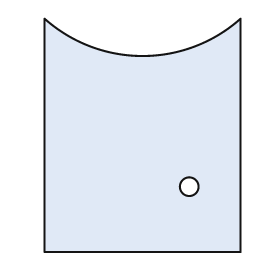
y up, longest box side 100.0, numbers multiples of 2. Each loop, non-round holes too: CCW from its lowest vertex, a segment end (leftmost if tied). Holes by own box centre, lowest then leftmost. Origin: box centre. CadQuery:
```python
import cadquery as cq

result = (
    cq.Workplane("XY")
    .moveTo(-42.0, -50.0)
    .lineTo(42.0, -50.0)
    .lineTo(42.0, 50.0)
    .threePointArc((0.0, 34.0), (-42.0, 50.0))
    .close()
    .moveTo(20.0, -22.0)
    .circle(4.0)
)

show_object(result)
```